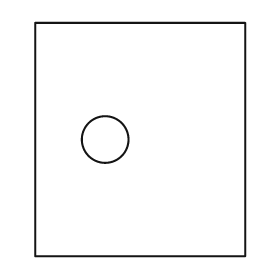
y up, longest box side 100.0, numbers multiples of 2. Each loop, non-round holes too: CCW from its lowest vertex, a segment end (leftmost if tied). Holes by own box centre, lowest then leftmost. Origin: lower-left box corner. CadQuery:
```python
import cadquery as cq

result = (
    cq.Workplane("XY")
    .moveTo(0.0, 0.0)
    .lineTo(90.0, 0.0)
    .lineTo(90.0, 100.0)
    .lineTo(0.0, 100.0)
    .close()
    .moveTo(30.0, 50.0)
    .circle(10.0)
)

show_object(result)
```